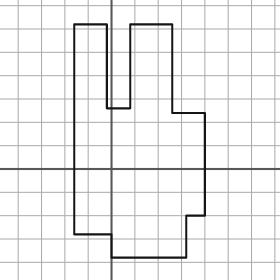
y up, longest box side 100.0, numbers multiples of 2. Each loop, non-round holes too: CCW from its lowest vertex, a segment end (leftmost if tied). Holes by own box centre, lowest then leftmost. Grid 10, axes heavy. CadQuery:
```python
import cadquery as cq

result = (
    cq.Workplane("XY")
    .moveTo(0.0, -38.0)
    .lineTo(32.0, -38.0)
    .lineTo(32.0, -20.0)
    .lineTo(40.0, -20.0)
    .lineTo(40.0, 24.0)
    .lineTo(26.0, 24.0)
    .lineTo(26.0, 62.0)
    .lineTo(8.0, 62.0)
    .lineTo(8.0, 26.0)
    .lineTo(-2.0, 26.0)
    .lineTo(-2.0, 62.0)
    .lineTo(-16.0, 62.0)
    .lineTo(-16.0, -28.0)
    .lineTo(0.0, -28.0)
    .close()
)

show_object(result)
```